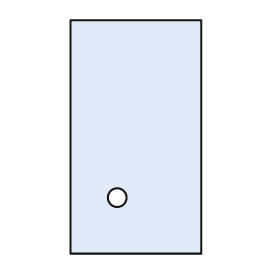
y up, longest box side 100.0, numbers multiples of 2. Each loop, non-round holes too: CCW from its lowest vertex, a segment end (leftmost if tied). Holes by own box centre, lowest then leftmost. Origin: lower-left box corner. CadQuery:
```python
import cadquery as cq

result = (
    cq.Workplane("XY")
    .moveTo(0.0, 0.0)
    .lineTo(56.0, 0.0)
    .lineTo(56.0, 100.0)
    .lineTo(0.0, 100.0)
    .close()
    .moveTo(20.0, 24.0)
    .circle(4.0)
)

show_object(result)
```